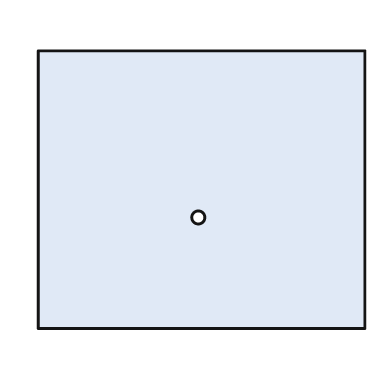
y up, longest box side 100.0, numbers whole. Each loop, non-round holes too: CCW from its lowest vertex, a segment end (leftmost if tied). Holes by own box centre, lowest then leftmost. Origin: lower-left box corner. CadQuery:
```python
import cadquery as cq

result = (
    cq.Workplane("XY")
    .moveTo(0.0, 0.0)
    .lineTo(100.0, 0.0)
    .lineTo(100.0, 85.0)
    .lineTo(0.0, 85.0)
    .close()
    .moveTo(49.0, 34.0)
    .circle(2.0)
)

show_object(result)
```